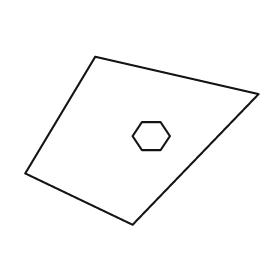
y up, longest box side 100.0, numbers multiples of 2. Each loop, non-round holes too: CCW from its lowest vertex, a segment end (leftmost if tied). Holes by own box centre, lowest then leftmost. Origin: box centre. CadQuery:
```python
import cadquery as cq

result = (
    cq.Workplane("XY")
    .moveTo(-4.0, -36.0)
    .lineTo(50.0, 20.0)
    .lineTo(-20.0, 36.0)
    .lineTo(-50.0, -14.0)
    .close()
    .moveTo(0.0, -4.0)
    .lineTo(8.0, -4.0)
    .lineTo(12.0, 2.0)
    .lineTo(8.0, 8.0)
    .lineTo(0.0, 8.0)
    .lineTo(-4.0, 2.0)
    .close()
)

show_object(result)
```